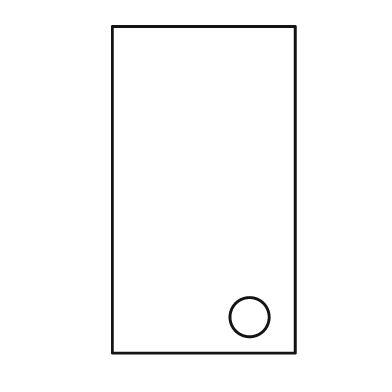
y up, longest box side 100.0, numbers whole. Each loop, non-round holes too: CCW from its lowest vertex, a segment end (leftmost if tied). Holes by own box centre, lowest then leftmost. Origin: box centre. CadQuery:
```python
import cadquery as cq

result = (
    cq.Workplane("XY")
    .moveTo(-28.0, -50.0)
    .lineTo(28.0, -50.0)
    .lineTo(28.0, 50.0)
    .lineTo(-28.0, 50.0)
    .close()
    .moveTo(14.0, -39.0)
    .circle(6.0)
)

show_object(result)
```